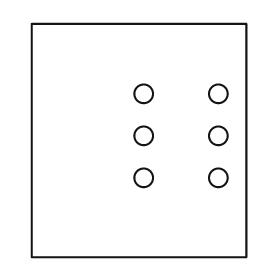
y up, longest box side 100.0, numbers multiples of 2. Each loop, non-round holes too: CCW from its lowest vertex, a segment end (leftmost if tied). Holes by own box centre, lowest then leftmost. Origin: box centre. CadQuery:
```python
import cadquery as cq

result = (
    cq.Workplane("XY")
    .moveTo(-46.0, -50.0)
    .lineTo(46.0, -50.0)
    .lineTo(46.0, 50.0)
    .lineTo(-46.0, 50.0)
    .close()
    .moveTo(2.0, -16.0)
    .circle(4.0)
    .moveTo(34.0, -16.0)
    .circle(4.0)
    .moveTo(2.0, 2.0)
    .circle(4.0)
    .moveTo(34.0, 2.0)
    .circle(4.0)
    .moveTo(2.0, 20.0)
    .circle(4.0)
    .moveTo(34.0, 20.0)
    .circle(4.0)
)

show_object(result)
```